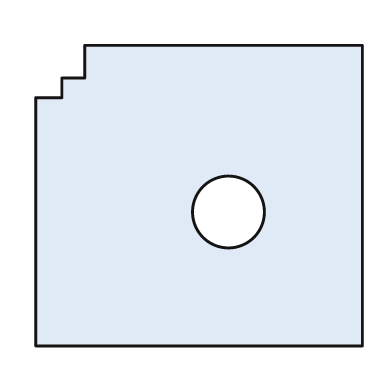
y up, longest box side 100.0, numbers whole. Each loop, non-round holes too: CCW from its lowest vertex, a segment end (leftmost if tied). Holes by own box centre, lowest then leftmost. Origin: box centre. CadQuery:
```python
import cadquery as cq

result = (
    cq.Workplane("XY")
    .moveTo(-50.0, -46.0)
    .lineTo(50.0, -46.0)
    .lineTo(50.0, 46.0)
    .lineTo(-35.0, 46.0)
    .lineTo(-35.0, 36.0)
    .lineTo(-42.0, 36.0)
    .lineTo(-42.0, 30.0)
    .lineTo(-50.0, 30.0)
    .close()
    .moveTo(9.0, -5.0)
    .circle(11.0)
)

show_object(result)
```